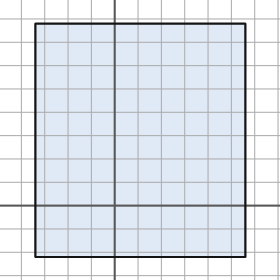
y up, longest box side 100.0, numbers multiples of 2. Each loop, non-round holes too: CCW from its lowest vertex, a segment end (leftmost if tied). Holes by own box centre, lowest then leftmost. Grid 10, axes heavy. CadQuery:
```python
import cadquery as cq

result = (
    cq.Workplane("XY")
    .moveTo(-34.0, -22.0)
    .lineTo(56.0, -22.0)
    .lineTo(56.0, 78.0)
    .lineTo(-34.0, 78.0)
    .close()
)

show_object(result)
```